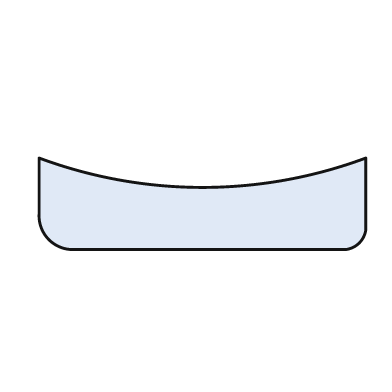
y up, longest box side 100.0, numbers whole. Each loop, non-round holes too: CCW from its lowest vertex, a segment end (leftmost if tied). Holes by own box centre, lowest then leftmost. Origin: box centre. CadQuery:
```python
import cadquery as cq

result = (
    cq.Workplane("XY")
    .moveTo(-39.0, -14.0)
    .lineTo(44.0, -14.0)
    .threePointArc((48.0, -12.0), (50.0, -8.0))
    .lineTo(50.0, 14.0)
    .threePointArc((0.0, 5.0), (-50.0, 14.0))
    .lineTo(-50.0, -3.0)
    .threePointArc((-47.0, -11.0), (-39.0, -14.0))
    .close()
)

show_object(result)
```